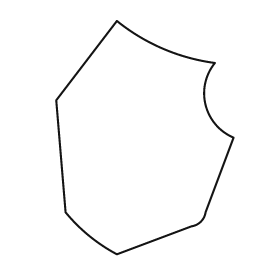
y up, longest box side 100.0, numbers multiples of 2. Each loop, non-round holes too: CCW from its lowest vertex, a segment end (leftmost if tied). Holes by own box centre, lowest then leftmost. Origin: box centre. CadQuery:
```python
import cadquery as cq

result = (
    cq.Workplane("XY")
    .moveTo(-12.0, -50.0)
    .lineTo(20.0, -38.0)
    .threePointArc((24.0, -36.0), (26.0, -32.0))
    .lineTo(38.0, 0.0)
    .threePointArc((26.0, 14.0), (30.0, 32.0))
    .threePointArc((8.0, 38.0), (-12.0, 50.0))
    .lineTo(-38.0, 16.0)
    .lineTo(-34.0, -32.0)
    .threePointArc((-24.0, -42.0), (-12.0, -50.0))
    .close()
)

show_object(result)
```